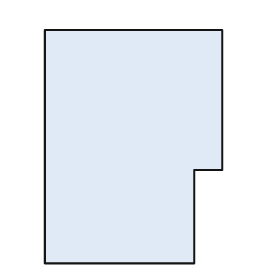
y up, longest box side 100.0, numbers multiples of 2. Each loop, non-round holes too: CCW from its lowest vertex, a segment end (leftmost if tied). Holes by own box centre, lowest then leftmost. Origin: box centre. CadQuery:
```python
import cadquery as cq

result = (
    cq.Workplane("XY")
    .moveTo(-38.0, -50.0)
    .lineTo(26.0, -50.0)
    .lineTo(26.0, -10.0)
    .lineTo(38.0, -10.0)
    .lineTo(38.0, 50.0)
    .lineTo(-38.0, 50.0)
    .close()
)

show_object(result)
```